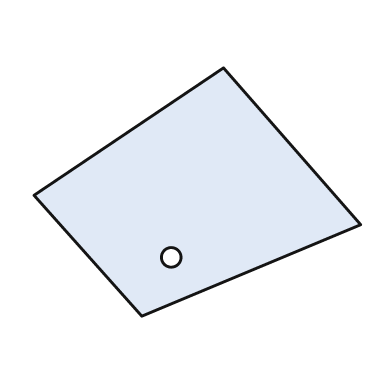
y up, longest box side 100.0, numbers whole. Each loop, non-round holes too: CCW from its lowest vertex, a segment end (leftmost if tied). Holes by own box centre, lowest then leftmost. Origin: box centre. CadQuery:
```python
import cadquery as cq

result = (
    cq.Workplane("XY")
    .moveTo(-17.0, -38.0)
    .lineTo(50.0, -10.0)
    .lineTo(8.0, 38.0)
    .lineTo(-50.0, -1.0)
    .close()
    .moveTo(-8.0, -20.0)
    .circle(3.0)
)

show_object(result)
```